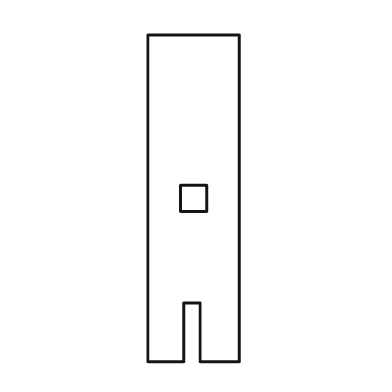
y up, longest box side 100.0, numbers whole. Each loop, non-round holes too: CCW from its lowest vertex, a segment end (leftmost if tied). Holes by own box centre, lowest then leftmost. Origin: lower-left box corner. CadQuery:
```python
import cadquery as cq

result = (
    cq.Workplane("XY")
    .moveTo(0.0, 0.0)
    .lineTo(11.0, 0.0)
    .lineTo(11.0, 18.0)
    .lineTo(16.0, 18.0)
    .lineTo(16.0, 0.0)
    .lineTo(28.0, 0.0)
    .lineTo(28.0, 100.0)
    .lineTo(0.0, 100.0)
    .close()
    .moveTo(10.0, 46.0)
    .lineTo(18.0, 46.0)
    .lineTo(18.0, 54.0)
    .lineTo(10.0, 54.0)
    .close()
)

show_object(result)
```